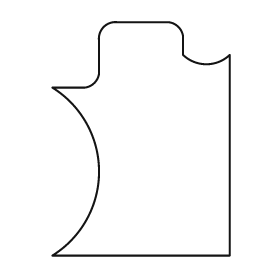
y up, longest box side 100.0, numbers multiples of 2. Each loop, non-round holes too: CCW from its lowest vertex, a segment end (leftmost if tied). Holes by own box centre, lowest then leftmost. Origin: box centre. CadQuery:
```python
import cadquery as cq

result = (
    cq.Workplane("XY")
    .moveTo(-38.0, -50.0)
    .lineTo(38.0, -50.0)
    .lineTo(38.0, 36.0)
    .threePointArc((28.0, 32.0), (18.0, 36.0))
    .lineTo(18.0, 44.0)
    .threePointArc((16.0, 48.0), (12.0, 50.0))
    .lineTo(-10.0, 50.0)
    .threePointArc((-16.0, 48.0), (-18.0, 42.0))
    .lineTo(-18.0, 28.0)
    .threePointArc((-20.0, 24.0), (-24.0, 22.0))
    .lineTo(-38.0, 22.0)
    .threePointArc((-18.0, -14.0), (-38.0, -50.0))
    .close()
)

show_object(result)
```